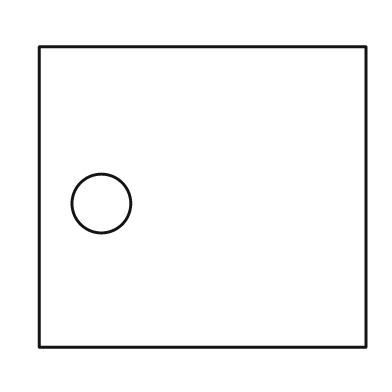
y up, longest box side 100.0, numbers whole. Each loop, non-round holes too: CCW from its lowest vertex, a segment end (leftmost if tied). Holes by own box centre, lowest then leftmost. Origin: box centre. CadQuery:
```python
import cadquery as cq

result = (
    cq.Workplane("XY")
    .moveTo(-50.0, -46.0)
    .lineTo(50.0, -46.0)
    .lineTo(50.0, 46.0)
    .lineTo(-50.0, 46.0)
    .close()
    .moveTo(-31.0, -2.0)
    .circle(9.0)
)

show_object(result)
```